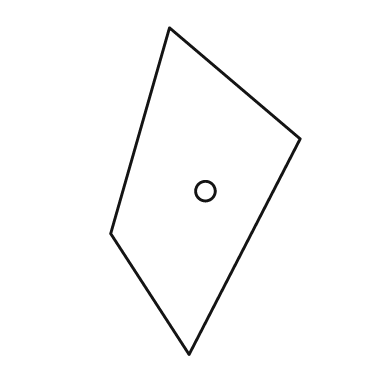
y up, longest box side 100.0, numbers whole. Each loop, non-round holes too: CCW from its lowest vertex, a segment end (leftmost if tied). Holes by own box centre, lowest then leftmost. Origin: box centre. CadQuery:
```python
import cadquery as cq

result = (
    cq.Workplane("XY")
    .moveTo(-5.0, -50.0)
    .lineTo(29.0, 16.0)
    .lineTo(-11.0, 50.0)
    .lineTo(-29.0, -13.0)
    .close()
    .moveTo(0.0, 0.0)
    .circle(3.0)
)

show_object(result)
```